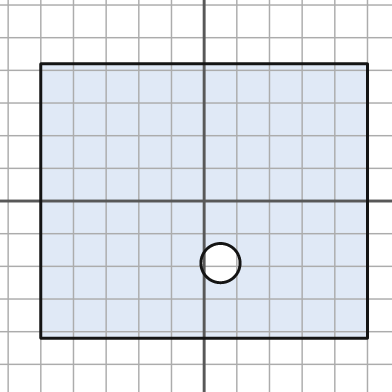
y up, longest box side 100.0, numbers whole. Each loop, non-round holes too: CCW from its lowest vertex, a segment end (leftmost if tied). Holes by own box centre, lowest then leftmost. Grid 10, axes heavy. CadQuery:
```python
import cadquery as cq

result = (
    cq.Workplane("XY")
    .moveTo(-50.0, -42.0)
    .lineTo(50.0, -42.0)
    .lineTo(50.0, 42.0)
    .lineTo(-50.0, 42.0)
    .close()
    .moveTo(5.0, -19.0)
    .circle(6.0)
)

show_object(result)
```